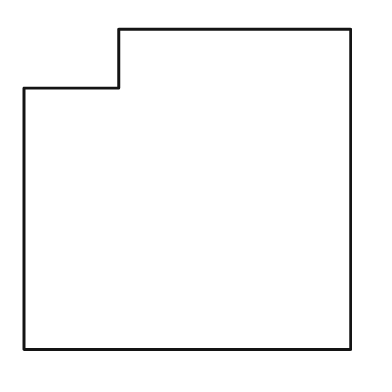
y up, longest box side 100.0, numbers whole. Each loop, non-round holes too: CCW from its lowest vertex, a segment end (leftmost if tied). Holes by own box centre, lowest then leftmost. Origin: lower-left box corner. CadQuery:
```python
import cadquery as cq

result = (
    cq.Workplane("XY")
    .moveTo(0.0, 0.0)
    .lineTo(100.0, 0.0)
    .lineTo(100.0, 98.0)
    .lineTo(29.0, 98.0)
    .lineTo(29.0, 80.0)
    .lineTo(0.0, 80.0)
    .close()
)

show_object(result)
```